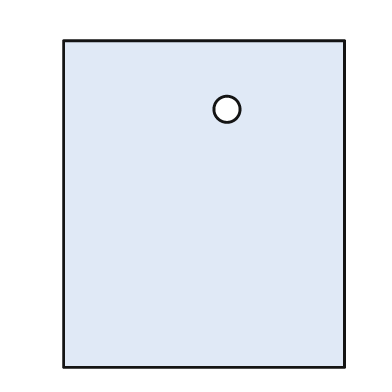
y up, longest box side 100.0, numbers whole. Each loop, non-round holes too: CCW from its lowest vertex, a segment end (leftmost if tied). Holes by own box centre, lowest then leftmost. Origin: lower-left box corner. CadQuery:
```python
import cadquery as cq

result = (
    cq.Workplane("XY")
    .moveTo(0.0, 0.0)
    .lineTo(86.0, 0.0)
    .lineTo(86.0, 100.0)
    .lineTo(0.0, 100.0)
    .close()
    .moveTo(50.0, 79.0)
    .circle(4.0)
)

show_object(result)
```